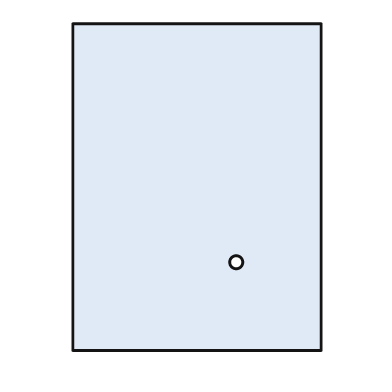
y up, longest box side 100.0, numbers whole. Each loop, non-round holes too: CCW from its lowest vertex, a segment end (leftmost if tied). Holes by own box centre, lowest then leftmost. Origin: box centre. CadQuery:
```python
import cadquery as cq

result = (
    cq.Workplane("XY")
    .moveTo(-38.0, -50.0)
    .lineTo(38.0, -50.0)
    .lineTo(38.0, 50.0)
    .lineTo(-38.0, 50.0)
    .close()
    .moveTo(12.0, -23.0)
    .circle(2.0)
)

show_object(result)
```